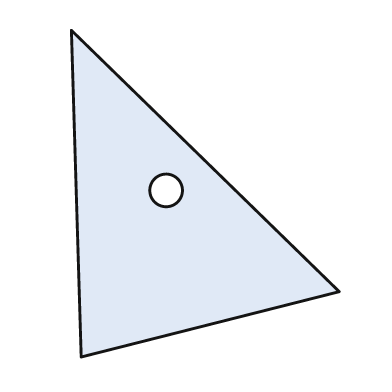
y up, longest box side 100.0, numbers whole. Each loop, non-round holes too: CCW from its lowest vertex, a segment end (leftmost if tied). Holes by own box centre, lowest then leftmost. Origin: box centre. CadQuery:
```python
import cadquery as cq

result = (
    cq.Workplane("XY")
    .moveTo(-38.0, -50.0)
    .lineTo(41.0, -30.0)
    .lineTo(-41.0, 50.0)
    .close()
    .moveTo(-12.0, 1.0)
    .circle(5.0)
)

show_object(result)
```